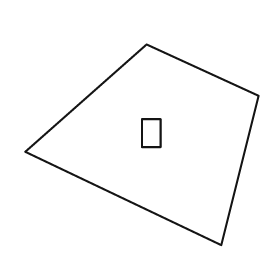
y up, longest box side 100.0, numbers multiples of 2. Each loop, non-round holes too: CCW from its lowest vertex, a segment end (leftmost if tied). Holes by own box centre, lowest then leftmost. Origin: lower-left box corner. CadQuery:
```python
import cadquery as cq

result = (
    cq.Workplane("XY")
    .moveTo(84.0, 0.0)
    .lineTo(100.0, 64.0)
    .lineTo(52.0, 86.0)
    .lineTo(0.0, 40.0)
    .close()
    .moveTo(50.0, 42.0)
    .lineTo(58.0, 42.0)
    .lineTo(58.0, 54.0)
    .lineTo(50.0, 54.0)
    .close()
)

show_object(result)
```